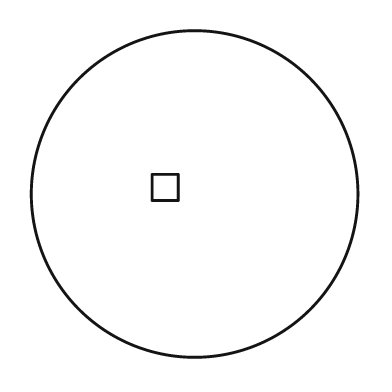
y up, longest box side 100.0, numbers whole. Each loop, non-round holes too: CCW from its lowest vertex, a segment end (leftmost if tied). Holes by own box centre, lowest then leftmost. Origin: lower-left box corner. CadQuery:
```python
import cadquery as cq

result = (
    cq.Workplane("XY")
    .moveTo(50.0, 50.0)
    .circle(50.0)
    .moveTo(37.0, 48.0)
    .lineTo(45.0, 48.0)
    .lineTo(45.0, 56.0)
    .lineTo(37.0, 56.0)
    .close()
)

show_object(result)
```